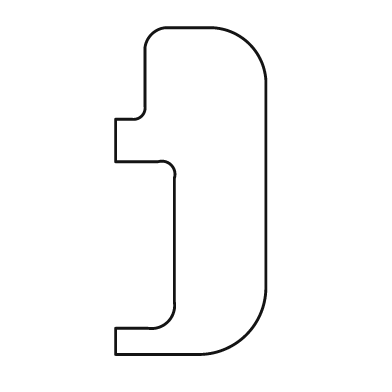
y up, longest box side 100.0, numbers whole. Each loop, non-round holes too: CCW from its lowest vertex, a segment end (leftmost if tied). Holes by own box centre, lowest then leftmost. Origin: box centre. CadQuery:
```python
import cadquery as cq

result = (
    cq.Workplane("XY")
    .moveTo(-23.0, -50.0)
    .lineTo(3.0, -50.0)
    .threePointArc((17.0, -44.0), (23.0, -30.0))
    .lineTo(23.0, 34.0)
    .threePointArc((18.0, 45.0), (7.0, 50.0))
    .lineTo(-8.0, 50.0)
    .threePointArc((-12.0, 48.0), (-14.0, 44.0))
    .lineTo(-14.0, 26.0)
    .threePointArc((-15.0, 23.0), (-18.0, 22.0))
    .lineTo(-23.0, 22.0)
    .lineTo(-23.0, 9.0)
    .lineTo(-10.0, 9.0)
    .threePointArc((-6.0, 8.0), (-5.0, 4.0))
    .lineTo(-5.0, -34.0)
    .threePointArc((-7.0, -40.0), (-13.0, -42.0))
    .lineTo(-23.0, -42.0)
    .close()
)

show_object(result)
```